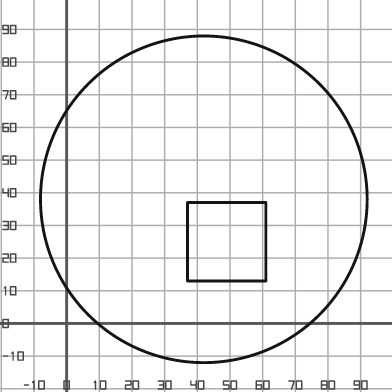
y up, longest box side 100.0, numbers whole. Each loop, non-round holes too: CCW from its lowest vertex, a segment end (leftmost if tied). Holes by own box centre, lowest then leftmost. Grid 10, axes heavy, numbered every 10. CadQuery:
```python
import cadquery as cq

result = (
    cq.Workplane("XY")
    .moveTo(42.0, 38.0)
    .circle(50.0)
    .moveTo(37.0, 13.0)
    .lineTo(61.0, 13.0)
    .lineTo(61.0, 37.0)
    .lineTo(37.0, 37.0)
    .close()
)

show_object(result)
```